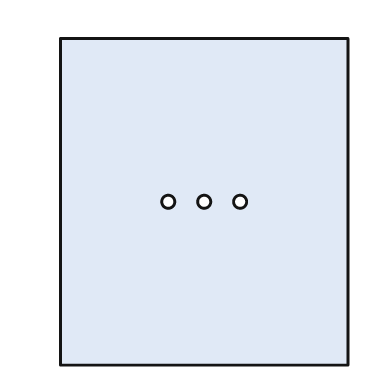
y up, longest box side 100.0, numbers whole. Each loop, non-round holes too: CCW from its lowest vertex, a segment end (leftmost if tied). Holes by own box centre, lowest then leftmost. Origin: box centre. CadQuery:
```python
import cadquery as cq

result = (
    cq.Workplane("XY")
    .moveTo(-44.0, -50.0)
    .lineTo(44.0, -50.0)
    .lineTo(44.0, 50.0)
    .lineTo(-44.0, 50.0)
    .close()
    .moveTo(-11.0, 0.0)
    .circle(2.0)
    .moveTo(0.0, 0.0)
    .circle(2.0)
    .moveTo(11.0, 0.0)
    .circle(2.0)
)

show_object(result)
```